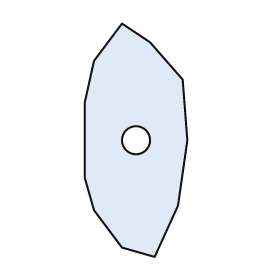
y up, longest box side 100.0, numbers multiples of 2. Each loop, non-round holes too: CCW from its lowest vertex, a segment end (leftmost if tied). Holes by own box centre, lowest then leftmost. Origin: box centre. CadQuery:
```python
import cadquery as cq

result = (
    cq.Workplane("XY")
    .moveTo(8.0, -50.0)
    .lineTo(18.0, -28.0)
    .lineTo(22.0, 0.0)
    .lineTo(20.0, 26.0)
    .lineTo(6.0, 42.0)
    .lineTo(-6.0, 50.0)
    .lineTo(-18.0, 34.0)
    .lineTo(-22.0, 16.0)
    .lineTo(-22.0, -16.0)
    .lineTo(-18.0, -30.0)
    .lineTo(-6.0, -46.0)
    .close()
    .moveTo(0.0, 0.0)
    .circle(6.0)
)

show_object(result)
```